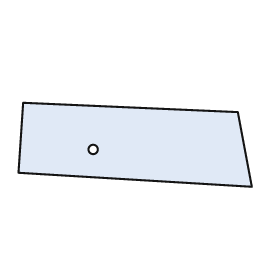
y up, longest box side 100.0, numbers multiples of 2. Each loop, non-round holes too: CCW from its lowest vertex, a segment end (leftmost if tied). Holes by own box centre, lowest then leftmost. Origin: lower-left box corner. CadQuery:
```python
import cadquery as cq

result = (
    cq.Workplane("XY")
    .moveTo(100.0, 0.0)
    .lineTo(94.0, 32.0)
    .lineTo(2.0, 36.0)
    .lineTo(0.0, 6.0)
    .close()
    .moveTo(32.0, 16.0)
    .circle(2.0)
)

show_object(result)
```